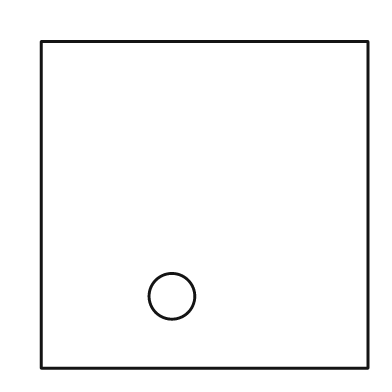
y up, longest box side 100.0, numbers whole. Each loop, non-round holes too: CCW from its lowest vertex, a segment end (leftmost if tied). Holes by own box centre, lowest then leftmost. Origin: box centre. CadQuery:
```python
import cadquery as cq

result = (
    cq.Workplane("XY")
    .moveTo(-50.0, -50.0)
    .lineTo(50.0, -50.0)
    .lineTo(50.0, 50.0)
    .lineTo(-50.0, 50.0)
    .close()
    .moveTo(-10.0, -28.0)
    .circle(7.0)
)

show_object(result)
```